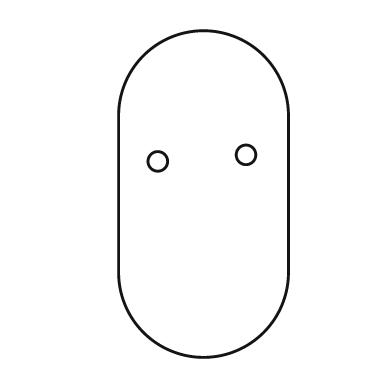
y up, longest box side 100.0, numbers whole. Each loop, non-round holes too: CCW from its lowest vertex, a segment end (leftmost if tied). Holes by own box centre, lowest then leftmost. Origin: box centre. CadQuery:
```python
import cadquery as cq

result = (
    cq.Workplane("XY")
    .moveTo(-26.0, -24.0)
    .threePointArc((0.0, -50.0), (26.0, -24.0))
    .lineTo(26.0, 24.0)
    .threePointArc((0.0, 50.0), (-26.0, 24.0))
    .close()
    .moveTo(-14.0, 10.0)
    .circle(3.0)
    .moveTo(13.0, 12.0)
    .circle(3.0)
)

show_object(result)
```